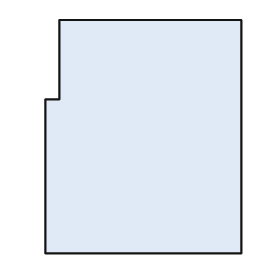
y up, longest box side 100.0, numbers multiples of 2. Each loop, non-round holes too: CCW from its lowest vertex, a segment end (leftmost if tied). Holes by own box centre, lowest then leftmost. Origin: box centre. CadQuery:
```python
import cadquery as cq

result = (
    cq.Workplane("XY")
    .moveTo(-42.0, -50.0)
    .lineTo(42.0, -50.0)
    .lineTo(42.0, 50.0)
    .lineTo(-36.0, 50.0)
    .lineTo(-36.0, 16.0)
    .lineTo(-42.0, 16.0)
    .close()
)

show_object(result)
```